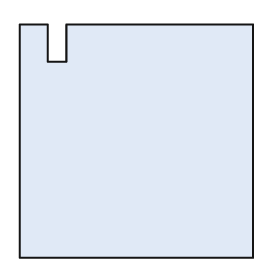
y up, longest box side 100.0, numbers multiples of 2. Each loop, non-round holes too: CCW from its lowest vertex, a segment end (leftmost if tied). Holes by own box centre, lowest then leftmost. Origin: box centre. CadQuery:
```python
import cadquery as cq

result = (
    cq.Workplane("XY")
    .moveTo(-50.0, -50.0)
    .lineTo(50.0, -50.0)
    .lineTo(50.0, 50.0)
    .lineTo(-30.0, 50.0)
    .lineTo(-30.0, 34.0)
    .lineTo(-38.0, 34.0)
    .lineTo(-38.0, 50.0)
    .lineTo(-50.0, 50.0)
    .close()
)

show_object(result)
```